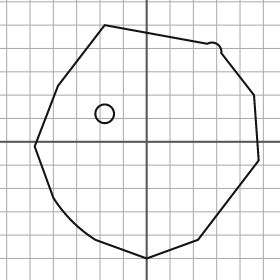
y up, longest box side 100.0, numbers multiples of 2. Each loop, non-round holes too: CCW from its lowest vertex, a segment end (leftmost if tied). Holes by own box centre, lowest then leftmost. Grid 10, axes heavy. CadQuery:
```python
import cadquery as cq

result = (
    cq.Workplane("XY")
    .moveTo(0.0, -50.0)
    .lineTo(22.0, -42.0)
    .lineTo(48.0, -8.0)
    .lineTo(46.0, 20.0)
    .lineTo(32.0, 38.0)
    .threePointArc((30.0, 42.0), (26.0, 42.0))
    .lineTo(-18.0, 50.0)
    .lineTo(-38.0, 24.0)
    .lineTo(-48.0, -2.0)
    .lineTo(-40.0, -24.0)
    .threePointArc((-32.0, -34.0), (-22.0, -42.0))
    .close()
    .moveTo(-18.0, 12.0)
    .circle(4.0)
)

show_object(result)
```